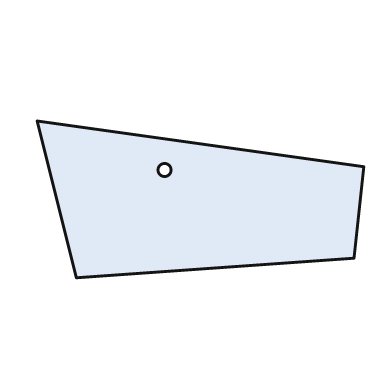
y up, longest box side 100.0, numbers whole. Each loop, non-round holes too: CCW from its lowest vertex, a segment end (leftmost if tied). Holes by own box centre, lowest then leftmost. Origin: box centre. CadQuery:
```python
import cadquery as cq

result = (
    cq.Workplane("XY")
    .moveTo(-38.0, -24.0)
    .lineTo(47.0, -18.0)
    .lineTo(50.0, 10.0)
    .lineTo(-50.0, 24.0)
    .close()
    .moveTo(-11.0, 9.0)
    .circle(2.0)
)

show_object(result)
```